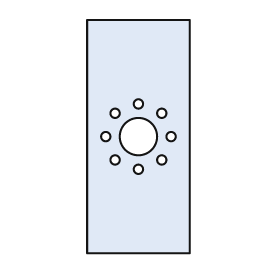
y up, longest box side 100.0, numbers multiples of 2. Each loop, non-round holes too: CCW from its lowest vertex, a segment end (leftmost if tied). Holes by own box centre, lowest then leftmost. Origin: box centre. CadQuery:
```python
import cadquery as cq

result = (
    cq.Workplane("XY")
    .moveTo(-22.0, -50.0)
    .lineTo(22.0, -50.0)
    .lineTo(22.0, 50.0)
    .lineTo(-22.0, 50.0)
    .close()
    .moveTo(0.0, -14.0)
    .circle(2.0)
    .moveTo(-10.0, -10.0)
    .circle(2.0)
    .moveTo(10.0, -10.0)
    .circle(2.0)
    .moveTo(-14.0, 0.0)
    .circle(2.0)
    .moveTo(0.0, 0.0)
    .circle(8.0)
    .moveTo(14.0, 0.0)
    .circle(2.0)
    .moveTo(-10.0, 10.0)
    .circle(2.0)
    .moveTo(10.0, 10.0)
    .circle(2.0)
    .moveTo(0.0, 14.0)
    .circle(2.0)
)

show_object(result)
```